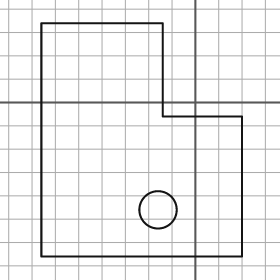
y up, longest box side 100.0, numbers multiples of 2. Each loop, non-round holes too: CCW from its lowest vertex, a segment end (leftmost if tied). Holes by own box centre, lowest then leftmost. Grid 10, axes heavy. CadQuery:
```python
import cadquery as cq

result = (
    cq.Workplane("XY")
    .moveTo(-66.0, -66.0)
    .lineTo(20.0, -66.0)
    .lineTo(20.0, -6.0)
    .lineTo(-14.0, -6.0)
    .lineTo(-14.0, 34.0)
    .lineTo(-66.0, 34.0)
    .close()
    .moveTo(-16.0, -46.0)
    .circle(8.0)
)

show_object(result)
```